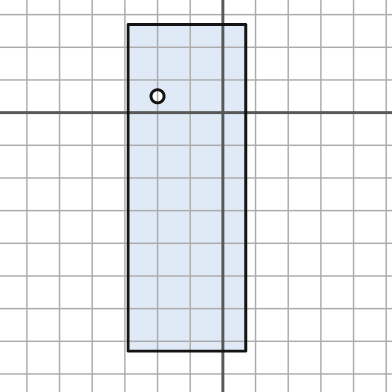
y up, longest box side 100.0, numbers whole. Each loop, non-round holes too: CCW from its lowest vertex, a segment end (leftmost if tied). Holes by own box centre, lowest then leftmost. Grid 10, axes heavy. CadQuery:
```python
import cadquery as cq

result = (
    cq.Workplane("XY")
    .moveTo(-29.0, -73.0)
    .lineTo(7.0, -73.0)
    .lineTo(7.0, 27.0)
    .lineTo(-29.0, 27.0)
    .close()
    .moveTo(-20.0, 5.0)
    .circle(2.0)
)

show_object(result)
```